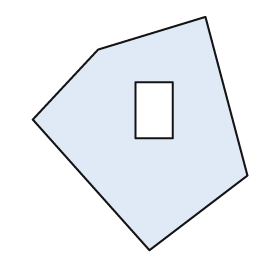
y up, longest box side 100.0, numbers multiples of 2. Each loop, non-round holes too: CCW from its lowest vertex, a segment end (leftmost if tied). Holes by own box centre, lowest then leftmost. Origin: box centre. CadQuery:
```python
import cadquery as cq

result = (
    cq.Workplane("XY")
    .moveTo(4.0, -50.0)
    .lineTo(46.0, -18.0)
    .lineTo(28.0, 50.0)
    .lineTo(-18.0, 36.0)
    .lineTo(-46.0, 6.0)
    .close()
    .moveTo(-2.0, -2.0)
    .lineTo(14.0, -2.0)
    .lineTo(14.0, 22.0)
    .lineTo(-2.0, 22.0)
    .close()
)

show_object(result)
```